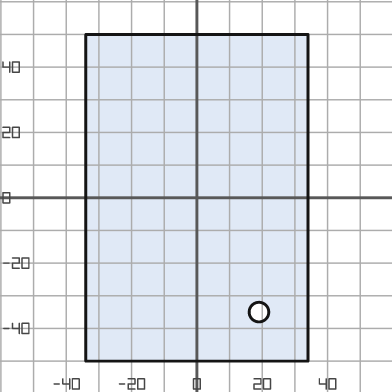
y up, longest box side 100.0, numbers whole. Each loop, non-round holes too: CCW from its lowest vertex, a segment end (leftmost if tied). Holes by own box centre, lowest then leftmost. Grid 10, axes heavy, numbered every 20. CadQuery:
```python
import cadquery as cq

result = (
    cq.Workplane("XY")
    .moveTo(-34.0, -50.0)
    .lineTo(34.0, -50.0)
    .lineTo(34.0, 50.0)
    .lineTo(-34.0, 50.0)
    .close()
    .moveTo(19.0, -35.0)
    .circle(3.0)
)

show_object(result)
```